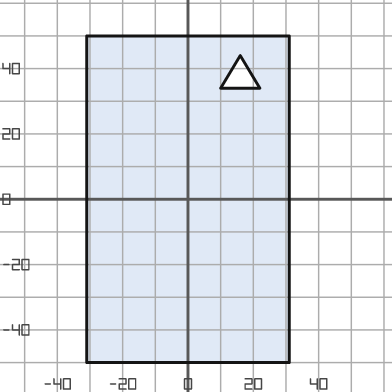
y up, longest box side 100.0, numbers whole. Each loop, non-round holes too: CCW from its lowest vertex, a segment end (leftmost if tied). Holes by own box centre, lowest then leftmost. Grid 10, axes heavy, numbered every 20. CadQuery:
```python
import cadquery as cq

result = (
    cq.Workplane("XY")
    .moveTo(-31.0, -50.0)
    .lineTo(31.0, -50.0)
    .lineTo(31.0, 50.0)
    .lineTo(-31.0, 50.0)
    .close()
    .moveTo(10.0, 34.0)
    .lineTo(22.0, 34.0)
    .lineTo(16.0, 44.0)
    .close()
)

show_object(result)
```